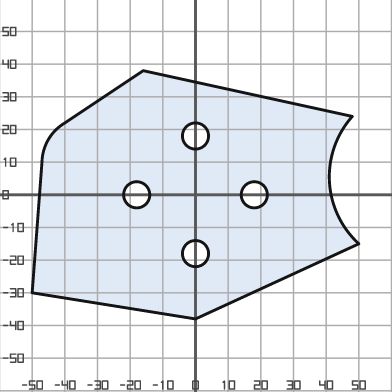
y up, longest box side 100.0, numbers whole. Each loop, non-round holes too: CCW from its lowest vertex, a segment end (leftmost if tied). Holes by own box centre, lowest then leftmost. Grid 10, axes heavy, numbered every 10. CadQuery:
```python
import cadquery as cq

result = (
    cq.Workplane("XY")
    .moveTo(0.0, -38.0)
    .lineTo(50.0, -15.0)
    .threePointArc((41.0, 4.0), (48.0, 24.0))
    .lineTo(-16.0, 38.0)
    .lineTo(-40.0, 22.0)
    .threePointArc((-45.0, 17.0), (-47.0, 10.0))
    .lineTo(-50.0, -30.0)
    .close()
    .moveTo(0.0, -18.0)
    .circle(4.0)
    .moveTo(-18.0, 0.0)
    .circle(4.0)
    .moveTo(18.0, 0.0)
    .circle(4.0)
    .moveTo(0.0, 18.0)
    .circle(4.0)
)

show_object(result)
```